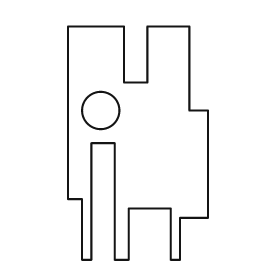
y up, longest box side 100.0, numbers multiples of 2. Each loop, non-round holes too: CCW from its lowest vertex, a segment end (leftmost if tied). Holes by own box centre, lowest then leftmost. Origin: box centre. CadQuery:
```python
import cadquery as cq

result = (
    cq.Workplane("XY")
    .moveTo(-24.0, -50.0)
    .lineTo(-20.0, -50.0)
    .lineTo(-20.0, 0.0)
    .lineTo(-10.0, 0.0)
    .lineTo(-10.0, -50.0)
    .lineTo(-4.0, -50.0)
    .lineTo(-4.0, -28.0)
    .lineTo(14.0, -28.0)
    .lineTo(14.0, -50.0)
    .lineTo(18.0, -50.0)
    .lineTo(18.0, -32.0)
    .lineTo(30.0, -32.0)
    .lineTo(30.0, 14.0)
    .lineTo(22.0, 14.0)
    .lineTo(22.0, 50.0)
    .lineTo(4.0, 50.0)
    .lineTo(4.0, 26.0)
    .lineTo(-6.0, 26.0)
    .lineTo(-6.0, 50.0)
    .lineTo(-30.0, 50.0)
    .lineTo(-30.0, -24.0)
    .lineTo(-24.0, -24.0)
    .close()
    .moveTo(-16.0, 14.0)
    .circle(8.0)
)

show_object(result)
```